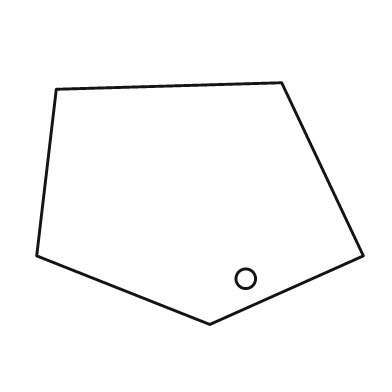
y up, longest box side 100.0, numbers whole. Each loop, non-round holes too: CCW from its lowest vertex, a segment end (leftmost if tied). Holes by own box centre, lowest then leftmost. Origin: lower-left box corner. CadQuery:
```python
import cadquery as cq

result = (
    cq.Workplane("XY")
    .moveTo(53.0, 0.0)
    .lineTo(100.0, 21.0)
    .lineTo(75.0, 74.0)
    .lineTo(6.0, 72.0)
    .lineTo(0.0, 21.0)
    .close()
    .moveTo(64.0, 14.0)
    .circle(3.0)
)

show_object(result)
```